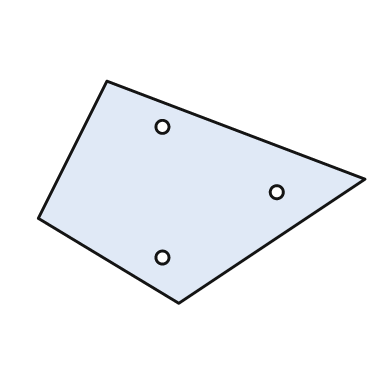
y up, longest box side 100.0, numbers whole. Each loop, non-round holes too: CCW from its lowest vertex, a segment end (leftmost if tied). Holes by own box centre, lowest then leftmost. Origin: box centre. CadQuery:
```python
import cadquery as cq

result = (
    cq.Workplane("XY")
    .moveTo(-7.0, -34.0)
    .lineTo(50.0, 4.0)
    .lineTo(-29.0, 34.0)
    .lineTo(-50.0, -8.0)
    .close()
    .moveTo(-12.0, -20.0)
    .circle(2.0)
    .moveTo(23.0, 0.0)
    .circle(2.0)
    .moveTo(-12.0, 20.0)
    .circle(2.0)
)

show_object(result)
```